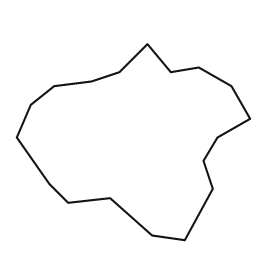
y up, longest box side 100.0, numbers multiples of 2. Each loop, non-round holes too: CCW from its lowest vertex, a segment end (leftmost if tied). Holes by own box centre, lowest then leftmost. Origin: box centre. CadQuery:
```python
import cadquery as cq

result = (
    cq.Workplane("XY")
    .moveTo(22.0, -42.0)
    .lineTo(34.0, -20.0)
    .lineTo(30.0, -8.0)
    .lineTo(36.0, 2.0)
    .lineTo(50.0, 10.0)
    .lineTo(42.0, 24.0)
    .lineTo(28.0, 32.0)
    .lineTo(16.0, 30.0)
    .lineTo(6.0, 42.0)
    .lineTo(-6.0, 30.0)
    .lineTo(-18.0, 26.0)
    .lineTo(-34.0, 24.0)
    .lineTo(-44.0, 16.0)
    .lineTo(-50.0, 2.0)
    .lineTo(-36.0, -18.0)
    .lineTo(-28.0, -26.0)
    .lineTo(-10.0, -24.0)
    .lineTo(8.0, -40.0)
    .close()
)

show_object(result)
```